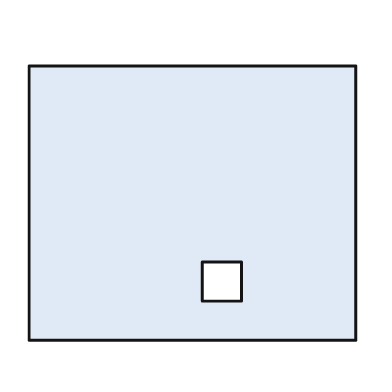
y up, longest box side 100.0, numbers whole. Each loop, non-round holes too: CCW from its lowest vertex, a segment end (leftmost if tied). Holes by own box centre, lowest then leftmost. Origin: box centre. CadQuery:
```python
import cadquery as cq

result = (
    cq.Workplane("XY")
    .moveTo(-50.0, -42.0)
    .lineTo(50.0, -42.0)
    .lineTo(50.0, 42.0)
    .lineTo(-50.0, 42.0)
    .close()
    .moveTo(3.0, -30.0)
    .lineTo(15.0, -30.0)
    .lineTo(15.0, -18.0)
    .lineTo(3.0, -18.0)
    .close()
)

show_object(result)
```